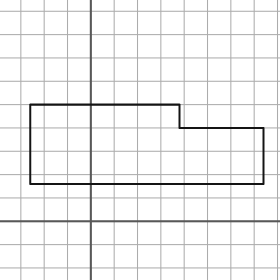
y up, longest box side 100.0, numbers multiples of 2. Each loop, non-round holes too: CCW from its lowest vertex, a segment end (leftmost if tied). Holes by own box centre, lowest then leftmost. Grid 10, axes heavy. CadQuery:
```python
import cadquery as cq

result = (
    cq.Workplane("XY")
    .moveTo(-26.0, 16.0)
    .lineTo(74.0, 16.0)
    .lineTo(74.0, 40.0)
    .lineTo(38.0, 40.0)
    .lineTo(38.0, 50.0)
    .lineTo(-26.0, 50.0)
    .close()
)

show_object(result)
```